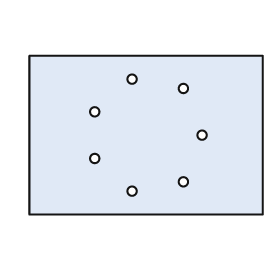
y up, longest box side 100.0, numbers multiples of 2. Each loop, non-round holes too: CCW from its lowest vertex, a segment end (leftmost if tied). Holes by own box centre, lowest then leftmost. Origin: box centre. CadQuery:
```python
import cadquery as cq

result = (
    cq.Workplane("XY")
    .moveTo(-50.0, -34.0)
    .lineTo(50.0, -34.0)
    .lineTo(50.0, 34.0)
    .lineTo(-50.0, 34.0)
    .close()
    .moveTo(-6.0, -24.0)
    .circle(2.0)
    .moveTo(16.0, -20.0)
    .circle(2.0)
    .moveTo(-22.0, -10.0)
    .circle(2.0)
    .moveTo(24.0, 0.0)
    .circle(2.0)
    .moveTo(-22.0, 10.0)
    .circle(2.0)
    .moveTo(16.0, 20.0)
    .circle(2.0)
    .moveTo(-6.0, 24.0)
    .circle(2.0)
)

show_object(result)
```